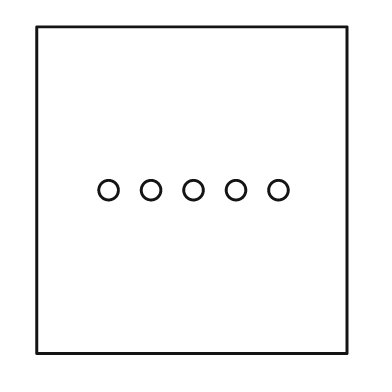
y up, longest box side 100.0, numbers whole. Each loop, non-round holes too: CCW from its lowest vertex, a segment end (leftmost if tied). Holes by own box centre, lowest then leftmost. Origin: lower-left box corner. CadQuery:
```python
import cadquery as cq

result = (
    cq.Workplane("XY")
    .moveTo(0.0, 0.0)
    .lineTo(95.0, 0.0)
    .lineTo(95.0, 100.0)
    .lineTo(0.0, 100.0)
    .close()
    .moveTo(22.0, 50.0)
    .circle(3.0)
    .moveTo(35.0, 50.0)
    .circle(3.0)
    .moveTo(48.0, 50.0)
    .circle(3.0)
    .moveTo(61.0, 50.0)
    .circle(3.0)
    .moveTo(74.0, 50.0)
    .circle(3.0)
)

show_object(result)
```